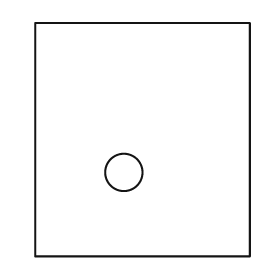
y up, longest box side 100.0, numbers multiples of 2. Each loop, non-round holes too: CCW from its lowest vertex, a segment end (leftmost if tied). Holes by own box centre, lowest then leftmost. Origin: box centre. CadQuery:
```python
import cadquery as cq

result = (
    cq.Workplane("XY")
    .moveTo(-46.0, -50.0)
    .lineTo(46.0, -50.0)
    .lineTo(46.0, 50.0)
    .lineTo(-46.0, 50.0)
    .close()
    .moveTo(-8.0, -14.0)
    .circle(8.0)
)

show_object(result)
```